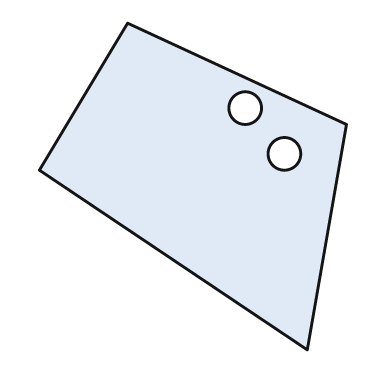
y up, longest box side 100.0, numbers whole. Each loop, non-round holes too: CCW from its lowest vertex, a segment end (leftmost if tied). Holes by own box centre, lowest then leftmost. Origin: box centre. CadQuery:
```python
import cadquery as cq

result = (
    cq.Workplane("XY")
    .moveTo(35.0, -50.0)
    .lineTo(47.0, 19.0)
    .lineTo(-20.0, 50.0)
    .lineTo(-47.0, 5.0)
    .close()
    .moveTo(28.0, 10.0)
    .circle(5.0)
    .moveTo(16.0, 24.0)
    .circle(5.0)
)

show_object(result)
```